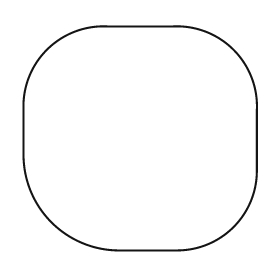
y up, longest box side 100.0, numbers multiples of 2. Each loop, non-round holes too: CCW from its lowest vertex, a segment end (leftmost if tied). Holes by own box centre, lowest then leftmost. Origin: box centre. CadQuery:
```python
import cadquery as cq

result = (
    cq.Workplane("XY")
    .moveTo(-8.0, -48.0)
    .lineTo(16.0, -48.0)
    .threePointArc((40.0, -38.0), (50.0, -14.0))
    .lineTo(50.0, 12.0)
    .threePointArc((40.0, 38.0), (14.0, 48.0))
    .lineTo(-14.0, 48.0)
    .threePointArc((-40.0, 38.0), (-50.0, 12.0))
    .lineTo(-50.0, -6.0)
    .threePointArc((-38.0, -36.0), (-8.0, -48.0))
    .close()
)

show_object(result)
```